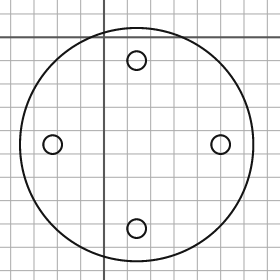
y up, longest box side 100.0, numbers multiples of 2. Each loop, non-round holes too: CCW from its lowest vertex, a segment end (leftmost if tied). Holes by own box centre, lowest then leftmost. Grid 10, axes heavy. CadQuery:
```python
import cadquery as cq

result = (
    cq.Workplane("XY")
    .moveTo(14.0, -46.0)
    .circle(50.0)
    .moveTo(14.0, -82.0)
    .circle(4.0)
    .moveTo(-22.0, -46.0)
    .circle(4.0)
    .moveTo(50.0, -46.0)
    .circle(4.0)
    .moveTo(14.0, -10.0)
    .circle(4.0)
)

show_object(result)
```